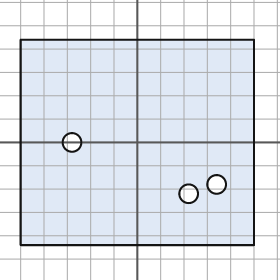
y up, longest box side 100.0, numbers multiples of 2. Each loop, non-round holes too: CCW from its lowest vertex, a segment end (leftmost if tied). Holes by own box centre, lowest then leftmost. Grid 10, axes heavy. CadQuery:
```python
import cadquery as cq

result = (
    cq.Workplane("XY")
    .moveTo(-50.0, -44.0)
    .lineTo(50.0, -44.0)
    .lineTo(50.0, 44.0)
    .lineTo(-50.0, 44.0)
    .close()
    .moveTo(22.0, -22.0)
    .circle(4.0)
    .moveTo(34.0, -18.0)
    .circle(4.0)
    .moveTo(-28.0, 0.0)
    .circle(4.0)
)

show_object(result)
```